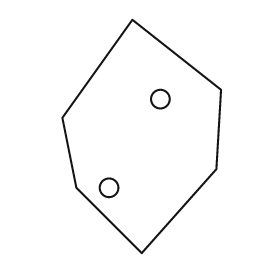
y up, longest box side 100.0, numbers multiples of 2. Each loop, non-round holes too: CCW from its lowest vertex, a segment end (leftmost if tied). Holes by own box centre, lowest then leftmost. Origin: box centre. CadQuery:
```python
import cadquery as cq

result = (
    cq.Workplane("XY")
    .moveTo(0.0, -50.0)
    .lineTo(32.0, -14.0)
    .lineTo(34.0, 20.0)
    .lineTo(-4.0, 50.0)
    .lineTo(-34.0, 8.0)
    .lineTo(-28.0, -22.0)
    .close()
    .moveTo(-14.0, -22.0)
    .circle(4.0)
    .moveTo(8.0, 16.0)
    .circle(4.0)
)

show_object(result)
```